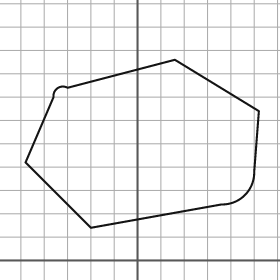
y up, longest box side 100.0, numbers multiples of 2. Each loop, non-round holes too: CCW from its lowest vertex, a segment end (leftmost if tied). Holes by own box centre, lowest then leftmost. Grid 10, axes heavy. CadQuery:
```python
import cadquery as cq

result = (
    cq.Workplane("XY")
    .moveTo(-20.0, 14.0)
    .lineTo(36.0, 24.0)
    .threePointArc((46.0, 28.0), (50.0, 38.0))
    .lineTo(52.0, 64.0)
    .lineTo(16.0, 86.0)
    .lineTo(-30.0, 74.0)
    .threePointArc((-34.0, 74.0), (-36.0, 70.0))
    .lineTo(-48.0, 42.0)
    .close()
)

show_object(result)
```